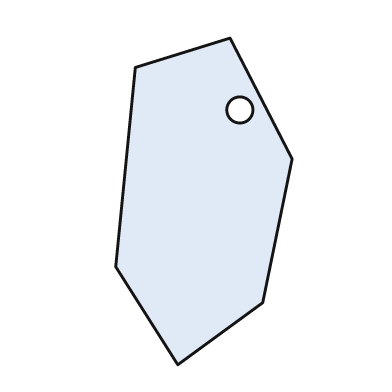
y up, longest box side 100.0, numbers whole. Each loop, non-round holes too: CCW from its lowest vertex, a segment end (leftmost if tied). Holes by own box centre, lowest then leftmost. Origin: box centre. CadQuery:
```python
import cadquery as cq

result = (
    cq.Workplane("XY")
    .moveTo(-8.0, -50.0)
    .lineTo(18.0, -31.0)
    .lineTo(27.0, 13.0)
    .lineTo(8.0, 50.0)
    .lineTo(-21.0, 41.0)
    .lineTo(-27.0, -20.0)
    .close()
    .moveTo(11.0, 28.0)
    .circle(4.0)
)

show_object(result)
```